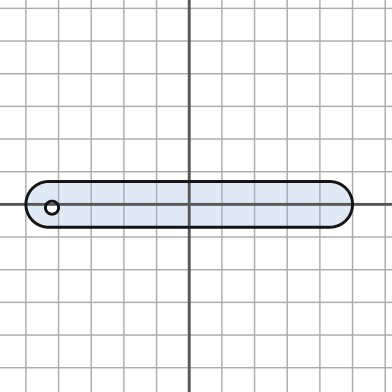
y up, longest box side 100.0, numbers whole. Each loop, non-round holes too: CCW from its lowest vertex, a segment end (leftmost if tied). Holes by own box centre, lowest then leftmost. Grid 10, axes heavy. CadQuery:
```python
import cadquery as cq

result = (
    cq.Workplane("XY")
    .moveTo(-43.0, -7.0)
    .lineTo(43.0, -7.0)
    .threePointArc((50.0, 0.0), (43.0, 7.0))
    .lineTo(-43.0, 7.0)
    .threePointArc((-50.0, 0.0), (-43.0, -7.0))
    .close()
    .moveTo(-42.0, -1.0)
    .circle(2.0)
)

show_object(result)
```